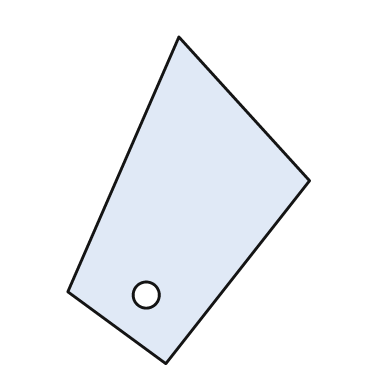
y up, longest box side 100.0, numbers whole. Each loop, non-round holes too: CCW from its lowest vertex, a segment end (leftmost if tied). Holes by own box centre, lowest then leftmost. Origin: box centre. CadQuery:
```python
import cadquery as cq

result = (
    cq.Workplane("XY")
    .moveTo(-7.0, -50.0)
    .lineTo(37.0, 6.0)
    .lineTo(-3.0, 50.0)
    .lineTo(-37.0, -28.0)
    .close()
    .moveTo(-13.0, -29.0)
    .circle(4.0)
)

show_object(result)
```